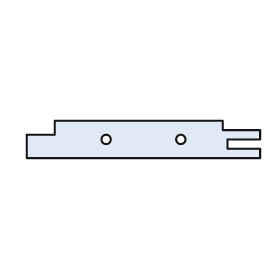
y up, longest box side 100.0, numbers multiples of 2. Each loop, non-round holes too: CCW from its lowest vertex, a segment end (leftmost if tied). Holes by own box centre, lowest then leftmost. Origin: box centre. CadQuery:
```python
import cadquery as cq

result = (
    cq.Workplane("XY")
    .moveTo(-50.0, -8.0)
    .lineTo(50.0, -8.0)
    .lineTo(50.0, -4.0)
    .lineTo(36.0, -4.0)
    .lineTo(36.0, 0.0)
    .lineTo(50.0, 0.0)
    .lineTo(50.0, 4.0)
    .lineTo(34.0, 4.0)
    .lineTo(34.0, 8.0)
    .lineTo(-38.0, 8.0)
    .lineTo(-38.0, 2.0)
    .lineTo(-50.0, 2.0)
    .close()
    .moveTo(-16.0, 0.0)
    .circle(2.0)
    .moveTo(16.0, 0.0)
    .circle(2.0)
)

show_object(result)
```